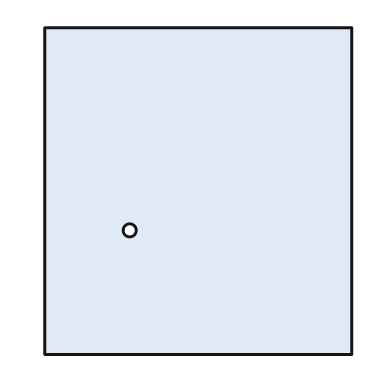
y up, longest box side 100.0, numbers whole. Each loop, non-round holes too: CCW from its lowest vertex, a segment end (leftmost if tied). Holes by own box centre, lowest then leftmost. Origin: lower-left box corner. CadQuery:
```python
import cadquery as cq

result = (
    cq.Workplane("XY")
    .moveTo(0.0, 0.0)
    .lineTo(94.0, 0.0)
    .lineTo(94.0, 100.0)
    .lineTo(0.0, 100.0)
    .close()
    .moveTo(26.0, 38.0)
    .circle(2.0)
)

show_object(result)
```